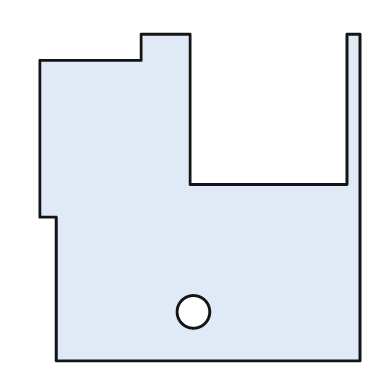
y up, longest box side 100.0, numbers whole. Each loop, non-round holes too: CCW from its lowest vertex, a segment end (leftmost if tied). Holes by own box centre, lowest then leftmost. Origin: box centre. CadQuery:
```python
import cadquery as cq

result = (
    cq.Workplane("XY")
    .moveTo(-44.0, -50.0)
    .lineTo(49.0, -50.0)
    .lineTo(49.0, 50.0)
    .lineTo(45.0, 50.0)
    .lineTo(45.0, 4.0)
    .lineTo(-3.0, 4.0)
    .lineTo(-3.0, 50.0)
    .lineTo(-18.0, 50.0)
    .lineTo(-18.0, 42.0)
    .lineTo(-49.0, 42.0)
    .lineTo(-49.0, -6.0)
    .lineTo(-44.0, -6.0)
    .close()
    .moveTo(-2.0, -35.0)
    .circle(5.0)
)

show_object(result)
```